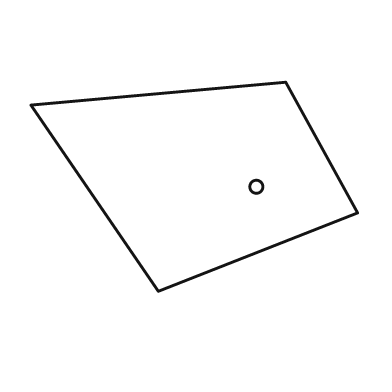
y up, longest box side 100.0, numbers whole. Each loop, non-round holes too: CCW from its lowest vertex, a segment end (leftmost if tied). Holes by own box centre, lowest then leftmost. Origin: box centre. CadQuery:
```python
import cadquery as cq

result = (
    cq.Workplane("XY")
    .moveTo(-11.0, -32.0)
    .lineTo(50.0, -8.0)
    .lineTo(28.0, 32.0)
    .lineTo(-50.0, 25.0)
    .close()
    .moveTo(19.0, 0.0)
    .circle(2.0)
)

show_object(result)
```